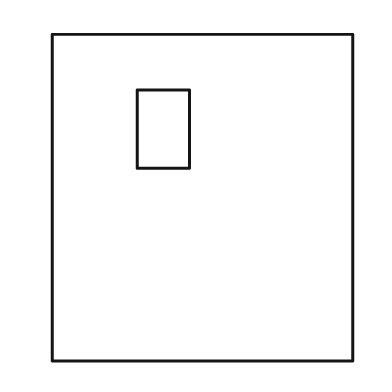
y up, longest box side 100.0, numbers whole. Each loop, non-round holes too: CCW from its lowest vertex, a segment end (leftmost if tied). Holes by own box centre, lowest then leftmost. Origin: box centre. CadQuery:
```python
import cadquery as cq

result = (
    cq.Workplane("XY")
    .moveTo(-46.0, -50.0)
    .lineTo(46.0, -50.0)
    .lineTo(46.0, 50.0)
    .lineTo(-46.0, 50.0)
    .close()
    .moveTo(-20.0, 9.0)
    .lineTo(-4.0, 9.0)
    .lineTo(-4.0, 33.0)
    .lineTo(-20.0, 33.0)
    .close()
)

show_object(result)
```